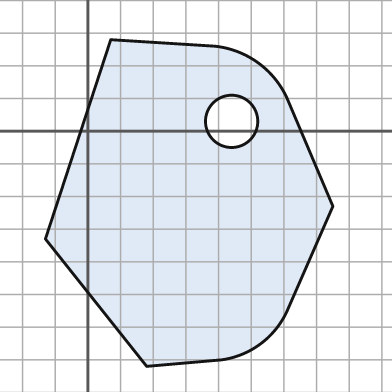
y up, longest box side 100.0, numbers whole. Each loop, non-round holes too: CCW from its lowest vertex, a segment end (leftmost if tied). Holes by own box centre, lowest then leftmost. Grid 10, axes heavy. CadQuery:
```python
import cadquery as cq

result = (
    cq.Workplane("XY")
    .moveTo(18.0, -72.0)
    .lineTo(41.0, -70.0)
    .threePointArc((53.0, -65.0), (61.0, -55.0))
    .lineTo(75.0, -23.0)
    .lineTo(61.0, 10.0)
    .threePointArc((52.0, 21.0), (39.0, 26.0))
    .lineTo(7.0, 28.0)
    .lineTo(-13.0, -33.0)
    .close()
    .moveTo(44.0, 3.0)
    .circle(8.0)
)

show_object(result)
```